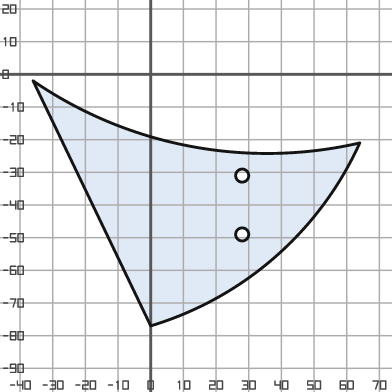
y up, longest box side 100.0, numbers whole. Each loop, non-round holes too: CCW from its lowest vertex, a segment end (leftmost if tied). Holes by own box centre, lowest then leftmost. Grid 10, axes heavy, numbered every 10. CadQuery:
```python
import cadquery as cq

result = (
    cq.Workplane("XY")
    .moveTo(0.0, -77.0)
    .threePointArc((38.0, -56.0), (64.0, -21.0))
    .threePointArc((12.0, -22.0), (-36.0, -2.0))
    .close()
    .moveTo(28.0, -49.0)
    .circle(2.0)
    .moveTo(28.0, -31.0)
    .circle(2.0)
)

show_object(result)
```